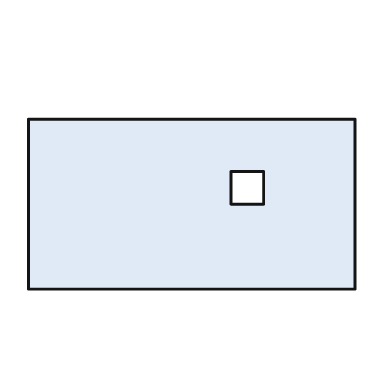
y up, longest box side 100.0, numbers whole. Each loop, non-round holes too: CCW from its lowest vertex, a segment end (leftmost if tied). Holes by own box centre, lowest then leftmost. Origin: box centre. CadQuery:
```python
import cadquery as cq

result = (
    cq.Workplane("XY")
    .moveTo(-50.0, -26.0)
    .lineTo(50.0, -26.0)
    .lineTo(50.0, 26.0)
    .lineTo(-50.0, 26.0)
    .close()
    .moveTo(12.0, 0.0)
    .lineTo(22.0, 0.0)
    .lineTo(22.0, 10.0)
    .lineTo(12.0, 10.0)
    .close()
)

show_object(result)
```